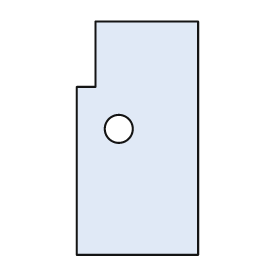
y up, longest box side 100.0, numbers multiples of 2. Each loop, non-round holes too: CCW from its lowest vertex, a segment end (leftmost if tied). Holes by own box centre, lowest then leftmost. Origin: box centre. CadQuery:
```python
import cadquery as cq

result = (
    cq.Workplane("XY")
    .moveTo(-26.0, -50.0)
    .lineTo(26.0, -50.0)
    .lineTo(26.0, 50.0)
    .lineTo(-18.0, 50.0)
    .lineTo(-18.0, 22.0)
    .lineTo(-26.0, 22.0)
    .close()
    .moveTo(-8.0, 4.0)
    .circle(6.0)
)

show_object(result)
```